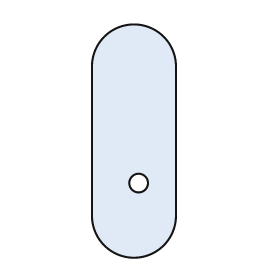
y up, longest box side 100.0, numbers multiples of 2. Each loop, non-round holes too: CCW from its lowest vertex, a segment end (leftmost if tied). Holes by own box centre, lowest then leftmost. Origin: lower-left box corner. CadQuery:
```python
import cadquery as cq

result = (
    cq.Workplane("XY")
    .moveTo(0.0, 18.0)
    .threePointArc((18.0, 0.0), (36.0, 18.0))
    .lineTo(36.0, 82.0)
    .threePointArc((18.0, 100.0), (0.0, 82.0))
    .close()
    .moveTo(20.0, 32.0)
    .circle(4.0)
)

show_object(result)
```